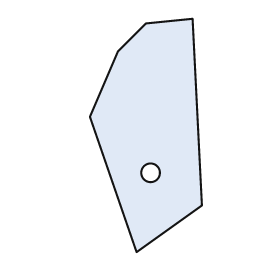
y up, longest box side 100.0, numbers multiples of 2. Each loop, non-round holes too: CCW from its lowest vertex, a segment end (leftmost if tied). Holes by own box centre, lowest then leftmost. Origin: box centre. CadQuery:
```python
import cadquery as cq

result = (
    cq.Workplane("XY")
    .moveTo(-4.0, -50.0)
    .lineTo(24.0, -30.0)
    .lineTo(20.0, 50.0)
    .lineTo(0.0, 48.0)
    .lineTo(-12.0, 36.0)
    .lineTo(-24.0, 8.0)
    .close()
    .moveTo(2.0, -16.0)
    .circle(4.0)
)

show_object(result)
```